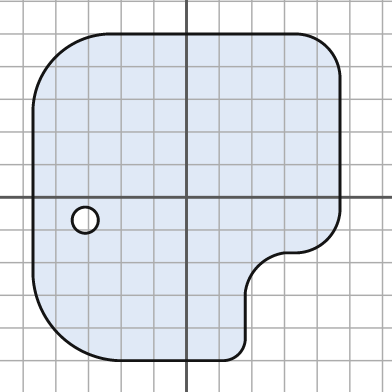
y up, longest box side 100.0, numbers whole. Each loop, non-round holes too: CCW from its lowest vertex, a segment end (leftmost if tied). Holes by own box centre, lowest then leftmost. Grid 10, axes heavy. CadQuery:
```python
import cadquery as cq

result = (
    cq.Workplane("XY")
    .moveTo(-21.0, -50.0)
    .lineTo(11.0, -50.0)
    .threePointArc((16.0, -48.0), (18.0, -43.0))
    .lineTo(18.0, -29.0)
    .threePointArc((22.0, -21.0), (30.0, -17.0))
    .lineTo(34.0, -17.0)
    .threePointArc((43.0, -13.0), (47.0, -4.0))
    .lineTo(47.0, 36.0)
    .threePointArc((43.0, 46.0), (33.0, 50.0))
    .lineTo(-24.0, 50.0)
    .threePointArc((-40.0, 43.0), (-47.0, 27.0))
    .lineTo(-47.0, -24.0)
    .threePointArc((-39.0, -42.0), (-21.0, -50.0))
    .close()
    .moveTo(-31.0, -7.0)
    .circle(4.0)
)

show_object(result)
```